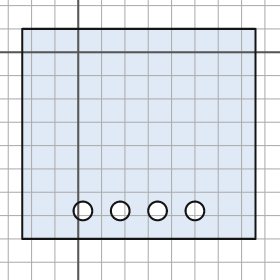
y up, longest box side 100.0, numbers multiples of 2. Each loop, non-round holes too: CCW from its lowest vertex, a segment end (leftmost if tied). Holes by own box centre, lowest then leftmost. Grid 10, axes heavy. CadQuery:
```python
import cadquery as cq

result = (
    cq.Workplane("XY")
    .moveTo(-24.0, -80.0)
    .lineTo(76.0, -80.0)
    .lineTo(76.0, 10.0)
    .lineTo(-24.0, 10.0)
    .close()
    .moveTo(2.0, -68.0)
    .circle(4.0)
    .moveTo(18.0, -68.0)
    .circle(4.0)
    .moveTo(34.0, -68.0)
    .circle(4.0)
    .moveTo(50.0, -68.0)
    .circle(4.0)
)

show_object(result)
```